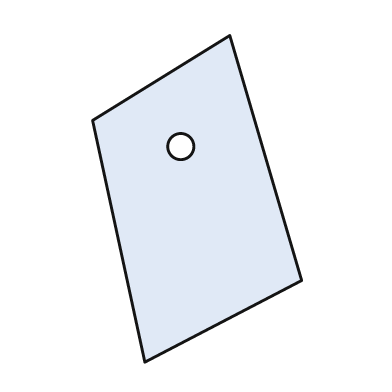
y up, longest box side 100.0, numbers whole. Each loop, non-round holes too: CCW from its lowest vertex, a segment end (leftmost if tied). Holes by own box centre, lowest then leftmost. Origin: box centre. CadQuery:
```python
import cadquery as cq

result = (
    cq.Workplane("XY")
    .moveTo(-16.0, -50.0)
    .lineTo(32.0, -25.0)
    .lineTo(10.0, 50.0)
    .lineTo(-32.0, 24.0)
    .close()
    .moveTo(-5.0, 16.0)
    .circle(4.0)
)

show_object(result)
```